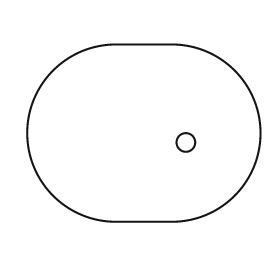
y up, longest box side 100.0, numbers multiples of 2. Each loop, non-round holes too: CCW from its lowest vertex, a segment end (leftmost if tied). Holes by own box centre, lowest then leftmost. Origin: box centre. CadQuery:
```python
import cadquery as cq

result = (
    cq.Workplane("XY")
    .moveTo(-12.0, -38.0)
    .lineTo(12.0, -38.0)
    .threePointArc((50.0, 0.0), (12.0, 38.0))
    .lineTo(-12.0, 38.0)
    .threePointArc((-50.0, 0.0), (-12.0, -38.0))
    .close()
    .moveTo(18.0, -4.0)
    .circle(4.0)
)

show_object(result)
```